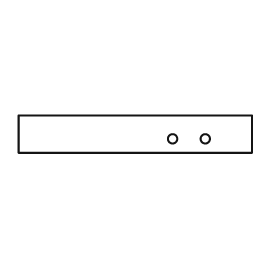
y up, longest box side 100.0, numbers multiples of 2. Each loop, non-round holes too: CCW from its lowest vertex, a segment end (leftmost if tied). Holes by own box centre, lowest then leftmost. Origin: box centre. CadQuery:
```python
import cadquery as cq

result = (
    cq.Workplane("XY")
    .moveTo(-50.0, -8.0)
    .lineTo(50.0, -8.0)
    .lineTo(50.0, 8.0)
    .lineTo(-50.0, 8.0)
    .close()
    .moveTo(16.0, -2.0)
    .circle(2.0)
    .moveTo(30.0, -2.0)
    .circle(2.0)
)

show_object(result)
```